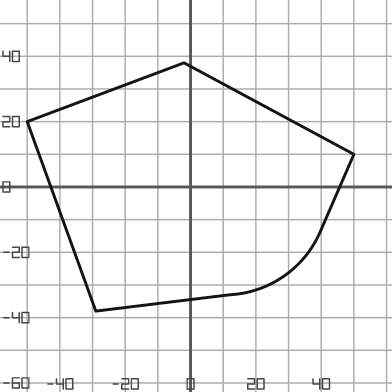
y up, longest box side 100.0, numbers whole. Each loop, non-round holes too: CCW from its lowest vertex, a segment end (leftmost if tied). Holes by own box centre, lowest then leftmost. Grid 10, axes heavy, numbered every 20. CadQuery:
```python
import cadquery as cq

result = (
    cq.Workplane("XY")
    .moveTo(-29.0, -38.0)
    .lineTo(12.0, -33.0)
    .threePointArc((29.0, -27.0), (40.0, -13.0))
    .lineTo(50.0, 10.0)
    .lineTo(-2.0, 38.0)
    .lineTo(-50.0, 20.0)
    .close()
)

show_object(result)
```